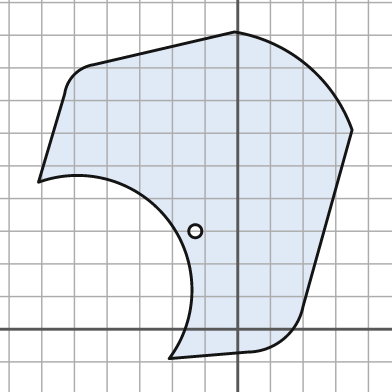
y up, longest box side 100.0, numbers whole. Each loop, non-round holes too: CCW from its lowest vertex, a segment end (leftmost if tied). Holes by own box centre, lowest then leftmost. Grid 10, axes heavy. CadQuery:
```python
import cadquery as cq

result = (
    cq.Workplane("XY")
    .moveTo(-21.0, -9.0)
    .lineTo(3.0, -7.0)
    .threePointArc((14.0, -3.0), (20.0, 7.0))
    .lineTo(35.0, 61.0)
    .threePointArc((21.0, 81.0), (-1.0, 91.0))
    .lineTo(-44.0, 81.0)
    .threePointArc((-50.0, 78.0), (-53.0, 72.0))
    .lineTo(-61.0, 45.0)
    .threePointArc((-21.0, 33.0), (-21.0, -9.0))
    .close()
    .moveTo(-13.0, 30.0)
    .circle(2.0)
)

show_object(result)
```